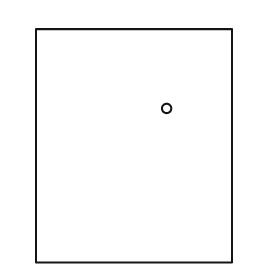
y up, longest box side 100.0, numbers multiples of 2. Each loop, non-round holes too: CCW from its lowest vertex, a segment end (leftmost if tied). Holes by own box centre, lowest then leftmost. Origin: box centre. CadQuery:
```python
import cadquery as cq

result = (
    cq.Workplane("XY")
    .moveTo(-42.0, -50.0)
    .lineTo(42.0, -50.0)
    .lineTo(42.0, 50.0)
    .lineTo(-42.0, 50.0)
    .close()
    .moveTo(14.0, 16.0)
    .circle(2.0)
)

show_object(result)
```